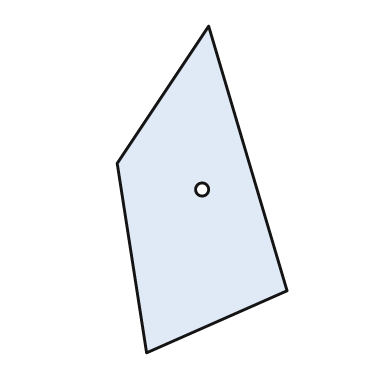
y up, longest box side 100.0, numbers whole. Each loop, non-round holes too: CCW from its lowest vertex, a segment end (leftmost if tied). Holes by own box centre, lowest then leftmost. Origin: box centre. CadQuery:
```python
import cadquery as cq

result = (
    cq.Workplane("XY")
    .moveTo(-17.0, -50.0)
    .lineTo(26.0, -31.0)
    .lineTo(2.0, 50.0)
    .lineTo(-26.0, 8.0)
    .close()
    .moveTo(0.0, 0.0)
    .circle(2.0)
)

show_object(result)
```